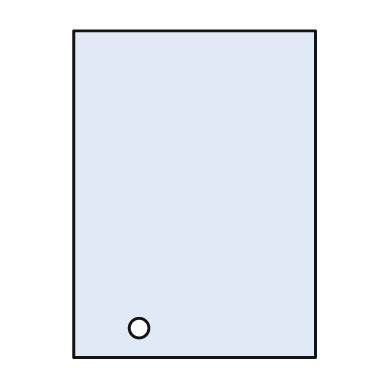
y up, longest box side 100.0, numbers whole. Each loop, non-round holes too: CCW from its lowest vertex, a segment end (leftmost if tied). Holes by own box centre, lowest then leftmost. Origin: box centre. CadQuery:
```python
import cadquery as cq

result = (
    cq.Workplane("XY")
    .moveTo(-37.0, -50.0)
    .lineTo(37.0, -50.0)
    .lineTo(37.0, 50.0)
    .lineTo(-37.0, 50.0)
    .close()
    .moveTo(-17.0, -41.0)
    .circle(3.0)
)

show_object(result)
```